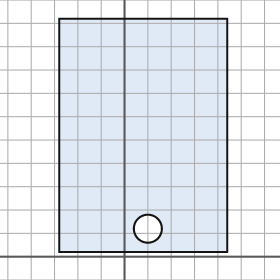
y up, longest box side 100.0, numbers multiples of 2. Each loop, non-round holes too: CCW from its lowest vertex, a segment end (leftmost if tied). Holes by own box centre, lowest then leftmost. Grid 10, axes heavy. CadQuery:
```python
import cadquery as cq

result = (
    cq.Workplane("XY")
    .moveTo(-28.0, 2.0)
    .lineTo(44.0, 2.0)
    .lineTo(44.0, 102.0)
    .lineTo(-28.0, 102.0)
    .close()
    .moveTo(10.0, 12.0)
    .circle(6.0)
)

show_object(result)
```